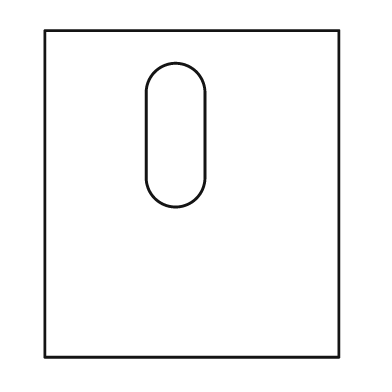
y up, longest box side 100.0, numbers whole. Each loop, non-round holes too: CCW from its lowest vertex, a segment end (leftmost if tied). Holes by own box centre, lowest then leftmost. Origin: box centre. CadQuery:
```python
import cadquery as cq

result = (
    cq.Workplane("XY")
    .moveTo(-45.0, -50.0)
    .lineTo(45.0, -50.0)
    .lineTo(45.0, 50.0)
    .lineTo(-45.0, 50.0)
    .close()
    .moveTo(-14.0, 5.0)
    .threePointArc((-5.0, -4.0), (4.0, 5.0))
    .lineTo(4.0, 31.0)
    .threePointArc((-5.0, 40.0), (-14.0, 31.0))
    .close()
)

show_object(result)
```